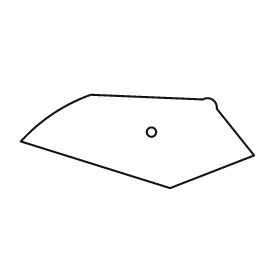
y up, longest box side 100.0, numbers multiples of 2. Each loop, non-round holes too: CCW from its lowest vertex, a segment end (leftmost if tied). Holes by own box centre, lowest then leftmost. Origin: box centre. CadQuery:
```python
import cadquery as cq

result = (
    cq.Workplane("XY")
    .moveTo(14.0, -20.0)
    .lineTo(50.0, -6.0)
    .lineTo(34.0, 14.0)
    .threePointArc((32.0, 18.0), (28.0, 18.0))
    .lineTo(-20.0, 20.0)
    .threePointArc((-36.0, 12.0), (-50.0, 0.0))
    .close()
    .moveTo(6.0, 4.0)
    .circle(2.0)
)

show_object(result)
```